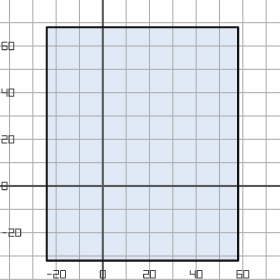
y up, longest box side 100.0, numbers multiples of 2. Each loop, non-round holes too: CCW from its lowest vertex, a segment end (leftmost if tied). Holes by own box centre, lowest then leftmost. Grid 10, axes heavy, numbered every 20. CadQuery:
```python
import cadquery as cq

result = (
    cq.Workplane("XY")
    .moveTo(-24.0, -32.0)
    .lineTo(58.0, -32.0)
    .lineTo(58.0, 68.0)
    .lineTo(-24.0, 68.0)
    .close()
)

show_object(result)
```